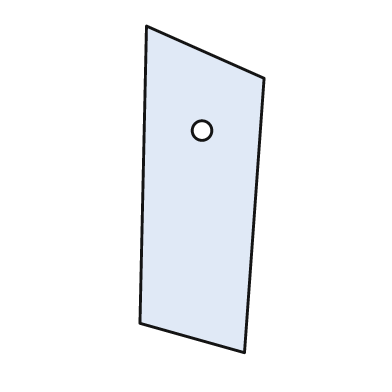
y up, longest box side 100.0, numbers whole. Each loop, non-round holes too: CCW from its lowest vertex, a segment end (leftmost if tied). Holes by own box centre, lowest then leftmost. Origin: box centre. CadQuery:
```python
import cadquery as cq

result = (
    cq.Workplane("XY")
    .moveTo(13.0, -50.0)
    .lineTo(19.0, 34.0)
    .lineTo(-17.0, 50.0)
    .lineTo(-19.0, -41.0)
    .close()
    .moveTo(0.0, 18.0)
    .circle(3.0)
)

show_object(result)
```